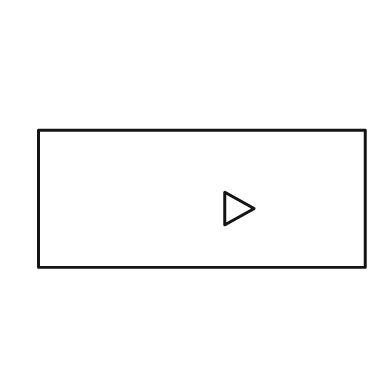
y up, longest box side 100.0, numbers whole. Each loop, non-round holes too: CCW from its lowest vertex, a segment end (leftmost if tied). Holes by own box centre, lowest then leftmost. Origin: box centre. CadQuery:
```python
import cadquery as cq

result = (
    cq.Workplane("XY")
    .moveTo(-50.0, -21.0)
    .lineTo(50.0, -21.0)
    .lineTo(50.0, 21.0)
    .lineTo(-50.0, 21.0)
    .close()
    .moveTo(7.0, -8.0)
    .lineTo(16.0, -3.0)
    .lineTo(7.0, 2.0)
    .close()
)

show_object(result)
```